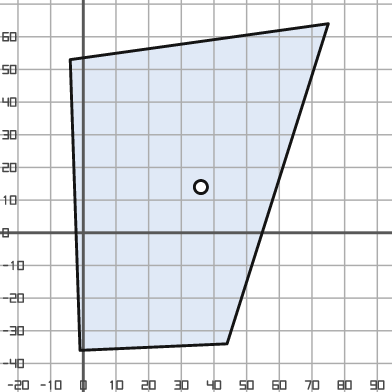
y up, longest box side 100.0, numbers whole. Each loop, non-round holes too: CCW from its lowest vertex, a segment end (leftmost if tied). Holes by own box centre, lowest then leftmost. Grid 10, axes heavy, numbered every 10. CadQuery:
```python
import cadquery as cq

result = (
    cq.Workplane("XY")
    .moveTo(-1.0, -36.0)
    .lineTo(44.0, -34.0)
    .lineTo(75.0, 64.0)
    .lineTo(-4.0, 53.0)
    .close()
    .moveTo(36.0, 14.0)
    .circle(2.0)
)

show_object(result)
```